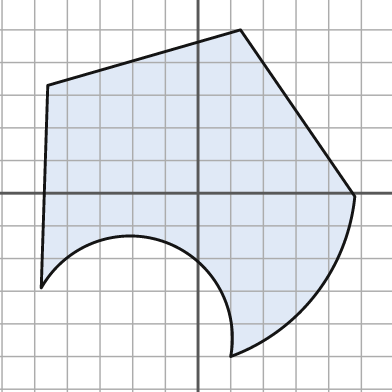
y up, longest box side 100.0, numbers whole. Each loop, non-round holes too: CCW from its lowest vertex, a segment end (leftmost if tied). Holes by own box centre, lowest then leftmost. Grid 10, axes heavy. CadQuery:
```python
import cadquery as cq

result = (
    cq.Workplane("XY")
    .moveTo(10.0, -50.0)
    .threePointArc((36.0, -31.0), (48.0, -1.0))
    .lineTo(13.0, 50.0)
    .lineTo(-46.0, 33.0)
    .lineTo(-48.0, -29.0)
    .threePointArc((-10.0, -15.0), (10.0, -50.0))
    .close()
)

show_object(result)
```